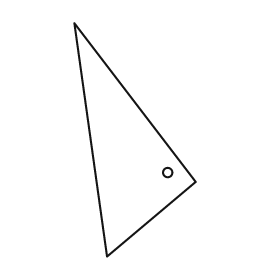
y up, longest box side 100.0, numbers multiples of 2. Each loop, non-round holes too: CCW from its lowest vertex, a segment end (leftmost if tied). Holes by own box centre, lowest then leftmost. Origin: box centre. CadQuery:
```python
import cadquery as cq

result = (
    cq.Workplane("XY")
    .moveTo(-12.0, -50.0)
    .lineTo(26.0, -18.0)
    .lineTo(-26.0, 50.0)
    .close()
    .moveTo(14.0, -14.0)
    .circle(2.0)
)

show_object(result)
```